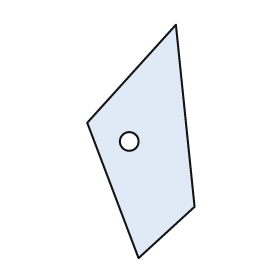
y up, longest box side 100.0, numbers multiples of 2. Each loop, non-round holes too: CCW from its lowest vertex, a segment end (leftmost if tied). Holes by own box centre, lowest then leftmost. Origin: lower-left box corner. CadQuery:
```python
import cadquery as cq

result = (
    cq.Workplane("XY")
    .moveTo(22.0, 0.0)
    .lineTo(46.0, 22.0)
    .lineTo(38.0, 100.0)
    .lineTo(0.0, 58.0)
    .close()
    .moveTo(18.0, 50.0)
    .circle(4.0)
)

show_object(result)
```